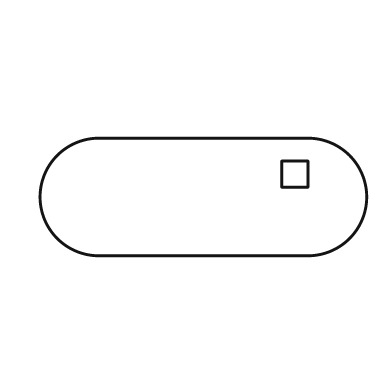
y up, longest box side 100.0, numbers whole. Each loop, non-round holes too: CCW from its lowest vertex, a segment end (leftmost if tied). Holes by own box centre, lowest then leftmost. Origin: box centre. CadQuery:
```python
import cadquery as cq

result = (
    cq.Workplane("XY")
    .moveTo(-32.0, -18.0)
    .lineTo(32.0, -18.0)
    .threePointArc((50.0, 0.0), (32.0, 18.0))
    .lineTo(-32.0, 18.0)
    .threePointArc((-50.0, 0.0), (-32.0, -18.0))
    .close()
    .moveTo(24.0, 3.0)
    .lineTo(32.0, 3.0)
    .lineTo(32.0, 11.0)
    .lineTo(24.0, 11.0)
    .close()
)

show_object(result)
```